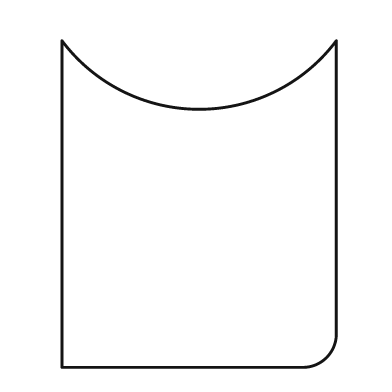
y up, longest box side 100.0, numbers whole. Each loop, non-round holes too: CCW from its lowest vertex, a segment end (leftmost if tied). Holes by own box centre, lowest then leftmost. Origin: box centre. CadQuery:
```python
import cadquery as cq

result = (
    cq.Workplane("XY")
    .moveTo(-42.0, -50.0)
    .lineTo(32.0, -50.0)
    .threePointArc((39.0, -47.0), (42.0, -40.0))
    .lineTo(42.0, 50.0)
    .threePointArc((0.0, 29.0), (-42.0, 50.0))
    .close()
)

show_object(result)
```